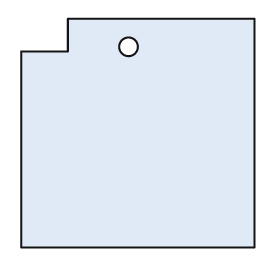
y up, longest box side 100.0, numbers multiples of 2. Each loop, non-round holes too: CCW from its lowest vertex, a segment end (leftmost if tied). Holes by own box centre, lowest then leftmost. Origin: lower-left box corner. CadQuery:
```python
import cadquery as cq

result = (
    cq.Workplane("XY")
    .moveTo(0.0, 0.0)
    .lineTo(100.0, 0.0)
    .lineTo(100.0, 98.0)
    .lineTo(20.0, 98.0)
    .lineTo(20.0, 84.0)
    .lineTo(0.0, 84.0)
    .close()
    .moveTo(46.0, 86.0)
    .circle(4.0)
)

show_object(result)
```